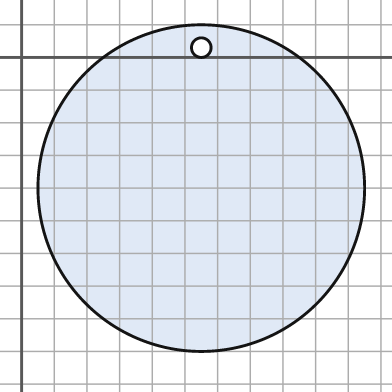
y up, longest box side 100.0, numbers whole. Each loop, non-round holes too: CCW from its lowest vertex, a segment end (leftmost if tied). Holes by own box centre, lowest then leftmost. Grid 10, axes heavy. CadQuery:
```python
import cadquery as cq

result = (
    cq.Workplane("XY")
    .moveTo(55.0, -40.0)
    .circle(50.0)
    .moveTo(55.0, 3.0)
    .circle(3.0)
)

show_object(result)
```